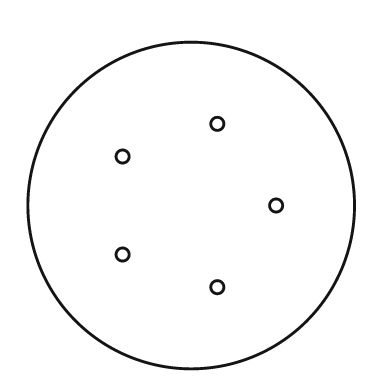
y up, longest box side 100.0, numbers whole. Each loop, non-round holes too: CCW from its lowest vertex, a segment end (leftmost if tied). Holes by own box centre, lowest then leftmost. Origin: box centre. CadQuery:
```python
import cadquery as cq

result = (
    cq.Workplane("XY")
    .moveTo(0.0, 0.0)
    .circle(50.0)
    .moveTo(8.0, -25.0)
    .circle(2.0)
    .moveTo(-21.0, -15.0)
    .circle(2.0)
    .moveTo(26.0, 0.0)
    .circle(2.0)
    .moveTo(-21.0, 15.0)
    .circle(2.0)
    .moveTo(8.0, 25.0)
    .circle(2.0)
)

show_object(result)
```